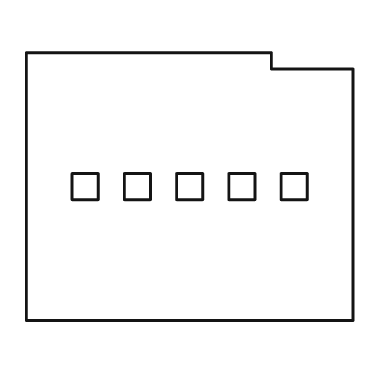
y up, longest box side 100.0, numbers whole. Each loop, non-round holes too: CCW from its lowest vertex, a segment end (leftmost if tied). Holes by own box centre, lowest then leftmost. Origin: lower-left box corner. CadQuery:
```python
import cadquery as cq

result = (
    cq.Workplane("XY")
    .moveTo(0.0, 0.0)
    .lineTo(100.0, 0.0)
    .lineTo(100.0, 77.0)
    .lineTo(75.0, 77.0)
    .lineTo(75.0, 82.0)
    .lineTo(0.0, 82.0)
    .close()
    .moveTo(14.0, 37.0)
    .lineTo(22.0, 37.0)
    .lineTo(22.0, 45.0)
    .lineTo(14.0, 45.0)
    .close()
    .moveTo(30.0, 37.0)
    .lineTo(38.0, 37.0)
    .lineTo(38.0, 45.0)
    .lineTo(30.0, 45.0)
    .close()
    .moveTo(46.0, 37.0)
    .lineTo(54.0, 37.0)
    .lineTo(54.0, 45.0)
    .lineTo(46.0, 45.0)
    .close()
    .moveTo(62.0, 37.0)
    .lineTo(70.0, 37.0)
    .lineTo(70.0, 45.0)
    .lineTo(62.0, 45.0)
    .close()
    .moveTo(78.0, 37.0)
    .lineTo(86.0, 37.0)
    .lineTo(86.0, 45.0)
    .lineTo(78.0, 45.0)
    .close()
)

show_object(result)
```